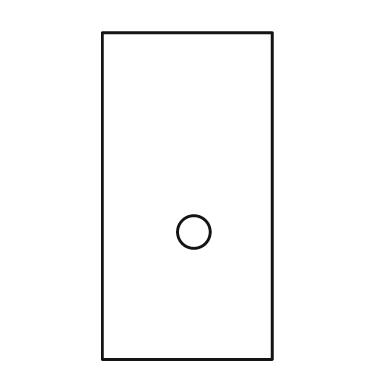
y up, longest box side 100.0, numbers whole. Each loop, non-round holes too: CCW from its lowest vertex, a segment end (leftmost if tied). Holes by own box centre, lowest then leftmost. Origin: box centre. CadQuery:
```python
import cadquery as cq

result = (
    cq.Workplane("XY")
    .moveTo(-26.0, -50.0)
    .lineTo(26.0, -50.0)
    .lineTo(26.0, 50.0)
    .lineTo(-26.0, 50.0)
    .close()
    .moveTo(2.0, -11.0)
    .circle(5.0)
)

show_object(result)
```